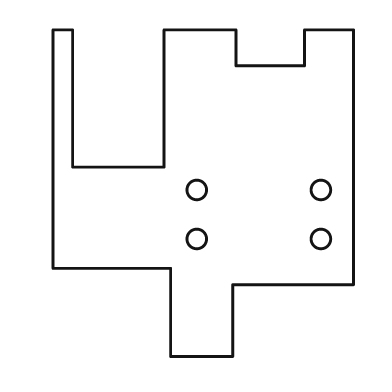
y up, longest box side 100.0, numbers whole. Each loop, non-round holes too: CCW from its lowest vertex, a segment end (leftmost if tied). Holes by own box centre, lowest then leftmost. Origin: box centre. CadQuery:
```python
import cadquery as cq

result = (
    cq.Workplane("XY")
    .moveTo(-10.0, -50.0)
    .lineTo(9.0, -50.0)
    .lineTo(9.0, -28.0)
    .lineTo(46.0, -28.0)
    .lineTo(46.0, 50.0)
    .lineTo(31.0, 50.0)
    .lineTo(31.0, 39.0)
    .lineTo(10.0, 39.0)
    .lineTo(10.0, 50.0)
    .lineTo(-12.0, 50.0)
    .lineTo(-12.0, 8.0)
    .lineTo(-40.0, 8.0)
    .lineTo(-40.0, 50.0)
    .lineTo(-46.0, 50.0)
    .lineTo(-46.0, -23.0)
    .lineTo(-10.0, -23.0)
    .close()
    .moveTo(-2.0, -14.0)
    .circle(3.0)
    .moveTo(36.0, -14.0)
    .circle(3.0)
    .moveTo(-2.0, 1.0)
    .circle(3.0)
    .moveTo(36.0, 1.0)
    .circle(3.0)
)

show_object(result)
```